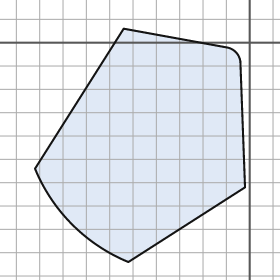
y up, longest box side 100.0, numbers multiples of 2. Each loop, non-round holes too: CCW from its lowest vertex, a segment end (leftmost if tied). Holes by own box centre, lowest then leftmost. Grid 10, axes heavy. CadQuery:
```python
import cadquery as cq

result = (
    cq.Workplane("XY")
    .moveTo(-52.0, -94.0)
    .lineTo(-2.0, -62.0)
    .lineTo(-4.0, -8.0)
    .threePointArc((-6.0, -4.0), (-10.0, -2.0))
    .lineTo(-54.0, 6.0)
    .lineTo(-92.0, -54.0)
    .threePointArc((-76.0, -78.0), (-52.0, -94.0))
    .close()
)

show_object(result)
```